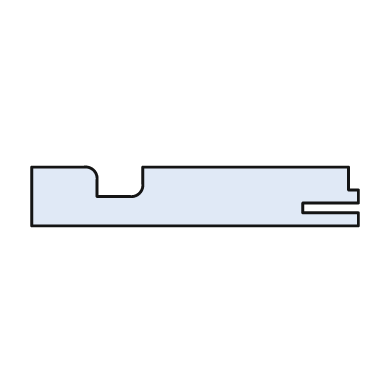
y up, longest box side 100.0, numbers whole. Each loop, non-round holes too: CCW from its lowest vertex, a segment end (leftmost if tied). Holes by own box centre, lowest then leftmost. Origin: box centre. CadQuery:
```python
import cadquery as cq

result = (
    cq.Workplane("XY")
    .moveTo(-50.0, -9.0)
    .lineTo(50.0, -9.0)
    .lineTo(50.0, -5.0)
    .lineTo(33.0, -5.0)
    .lineTo(33.0, -2.0)
    .lineTo(50.0, -2.0)
    .lineTo(50.0, 2.0)
    .lineTo(47.0, 2.0)
    .lineTo(47.0, 9.0)
    .lineTo(-16.0, 9.0)
    .lineTo(-16.0, 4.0)
    .threePointArc((-17.0, 1.0), (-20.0, 0.0))
    .lineTo(-30.0, 0.0)
    .lineTo(-30.0, 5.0)
    .threePointArc((-31.0, 8.0), (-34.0, 9.0))
    .lineTo(-50.0, 9.0)
    .close()
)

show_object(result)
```